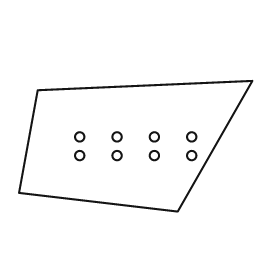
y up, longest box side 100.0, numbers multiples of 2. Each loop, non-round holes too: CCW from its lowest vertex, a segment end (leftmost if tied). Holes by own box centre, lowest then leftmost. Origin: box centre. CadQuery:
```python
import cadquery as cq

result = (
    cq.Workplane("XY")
    .moveTo(18.0, -28.0)
    .lineTo(50.0, 28.0)
    .lineTo(-42.0, 24.0)
    .lineTo(-50.0, -20.0)
    .close()
    .moveTo(-24.0, -4.0)
    .circle(2.0)
    .moveTo(-8.0, -4.0)
    .circle(2.0)
    .moveTo(8.0, -4.0)
    .circle(2.0)
    .moveTo(24.0, -4.0)
    .circle(2.0)
    .moveTo(-24.0, 4.0)
    .circle(2.0)
    .moveTo(-8.0, 4.0)
    .circle(2.0)
    .moveTo(8.0, 4.0)
    .circle(2.0)
    .moveTo(24.0, 4.0)
    .circle(2.0)
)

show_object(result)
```